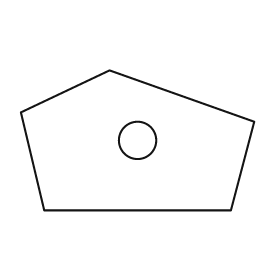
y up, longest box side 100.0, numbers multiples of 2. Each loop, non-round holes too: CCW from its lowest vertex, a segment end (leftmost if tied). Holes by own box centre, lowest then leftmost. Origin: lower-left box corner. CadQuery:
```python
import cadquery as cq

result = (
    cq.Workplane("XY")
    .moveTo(10.0, 0.0)
    .lineTo(90.0, 0.0)
    .lineTo(100.0, 38.0)
    .lineTo(38.0, 60.0)
    .lineTo(0.0, 42.0)
    .close()
    .moveTo(50.0, 30.0)
    .circle(8.0)
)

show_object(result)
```